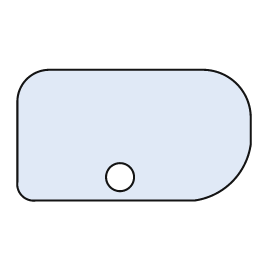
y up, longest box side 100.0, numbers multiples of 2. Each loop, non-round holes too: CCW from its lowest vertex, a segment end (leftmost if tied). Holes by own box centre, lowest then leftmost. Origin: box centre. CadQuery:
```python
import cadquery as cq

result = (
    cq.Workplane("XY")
    .moveTo(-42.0, -28.0)
    .lineTo(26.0, -28.0)
    .threePointArc((42.0, -20.0), (50.0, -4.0))
    .lineTo(50.0, 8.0)
    .threePointArc((44.0, 22.0), (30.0, 28.0))
    .lineTo(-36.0, 28.0)
    .threePointArc((-46.0, 24.0), (-50.0, 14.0))
    .lineTo(-50.0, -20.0)
    .threePointArc((-48.0, -26.0), (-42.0, -28.0))
    .close()
    .moveTo(-6.0, -18.0)
    .circle(6.0)
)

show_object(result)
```